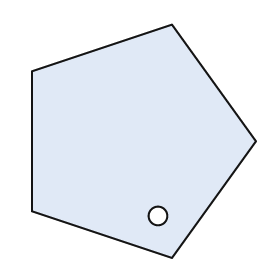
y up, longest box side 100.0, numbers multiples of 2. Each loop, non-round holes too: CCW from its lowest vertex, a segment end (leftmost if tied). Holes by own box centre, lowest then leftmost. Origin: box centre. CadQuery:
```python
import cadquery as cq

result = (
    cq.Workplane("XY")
    .moveTo(12.0, -50.0)
    .lineTo(48.0, 0.0)
    .lineTo(12.0, 50.0)
    .lineTo(-48.0, 30.0)
    .lineTo(-48.0, -30.0)
    .close()
    .moveTo(6.0, -32.0)
    .circle(4.0)
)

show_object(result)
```